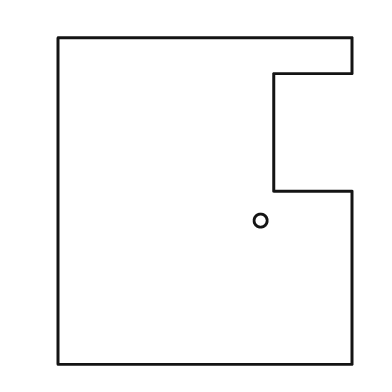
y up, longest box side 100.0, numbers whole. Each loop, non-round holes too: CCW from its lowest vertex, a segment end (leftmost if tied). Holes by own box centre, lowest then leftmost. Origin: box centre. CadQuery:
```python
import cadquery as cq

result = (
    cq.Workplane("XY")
    .moveTo(-45.0, -50.0)
    .lineTo(45.0, -50.0)
    .lineTo(45.0, 3.0)
    .lineTo(21.0, 3.0)
    .lineTo(21.0, 39.0)
    .lineTo(45.0, 39.0)
    .lineTo(45.0, 50.0)
    .lineTo(-45.0, 50.0)
    .close()
    .moveTo(17.0, -6.0)
    .circle(2.0)
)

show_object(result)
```